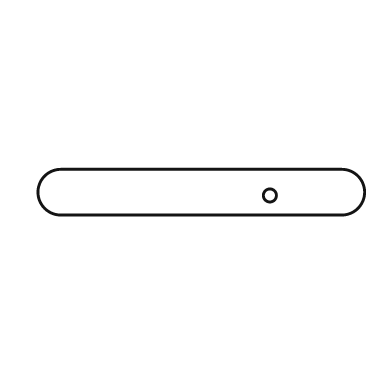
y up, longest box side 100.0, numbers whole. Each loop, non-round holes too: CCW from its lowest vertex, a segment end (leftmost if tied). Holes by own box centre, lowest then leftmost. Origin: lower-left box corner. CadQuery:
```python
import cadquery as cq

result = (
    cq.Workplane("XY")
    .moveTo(7.0, 0.0)
    .lineTo(93.0, 0.0)
    .threePointArc((100.0, 7.0), (93.0, 14.0))
    .lineTo(7.0, 14.0)
    .threePointArc((0.0, 7.0), (7.0, 0.0))
    .close()
    .moveTo(71.0, 6.0)
    .circle(2.0)
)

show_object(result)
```